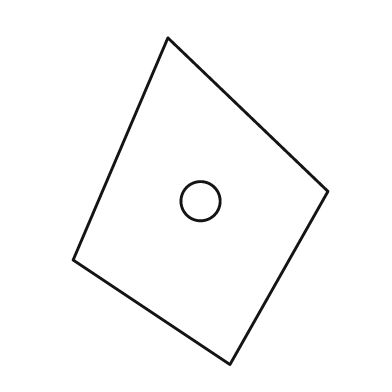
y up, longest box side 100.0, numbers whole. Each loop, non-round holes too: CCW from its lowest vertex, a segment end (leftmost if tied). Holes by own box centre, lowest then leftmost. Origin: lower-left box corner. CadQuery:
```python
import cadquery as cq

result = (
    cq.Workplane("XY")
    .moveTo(48.0, 0.0)
    .lineTo(78.0, 53.0)
    .lineTo(29.0, 100.0)
    .lineTo(0.0, 32.0)
    .close()
    .moveTo(39.0, 50.0)
    .circle(6.0)
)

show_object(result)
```